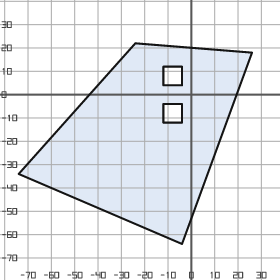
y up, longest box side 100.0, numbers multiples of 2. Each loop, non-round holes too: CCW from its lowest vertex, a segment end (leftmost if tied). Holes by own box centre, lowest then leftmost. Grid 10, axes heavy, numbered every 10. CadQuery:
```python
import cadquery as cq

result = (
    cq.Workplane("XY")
    .moveTo(-4.0, -64.0)
    .lineTo(26.0, 18.0)
    .lineTo(-24.0, 22.0)
    .lineTo(-74.0, -34.0)
    .close()
    .moveTo(-12.0, -12.0)
    .lineTo(-4.0, -12.0)
    .lineTo(-4.0, -4.0)
    .lineTo(-12.0, -4.0)
    .close()
    .moveTo(-12.0, 4.0)
    .lineTo(-4.0, 4.0)
    .lineTo(-4.0, 12.0)
    .lineTo(-12.0, 12.0)
    .close()
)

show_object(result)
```